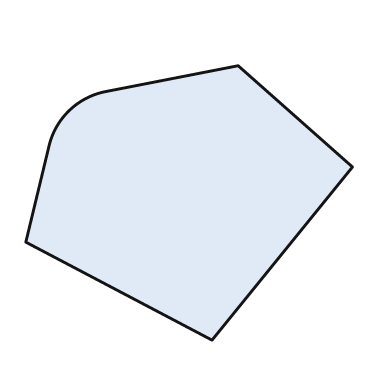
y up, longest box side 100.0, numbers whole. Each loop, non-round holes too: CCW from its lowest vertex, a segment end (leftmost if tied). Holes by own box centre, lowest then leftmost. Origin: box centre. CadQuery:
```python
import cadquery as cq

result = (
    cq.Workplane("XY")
    .moveTo(7.0, -42.0)
    .lineTo(50.0, 11.0)
    .lineTo(15.0, 42.0)
    .lineTo(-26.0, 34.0)
    .threePointArc((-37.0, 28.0), (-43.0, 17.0))
    .lineTo(-50.0, -12.0)
    .close()
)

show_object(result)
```